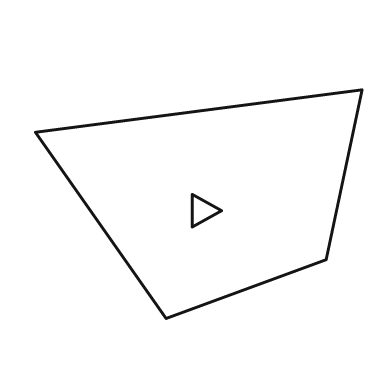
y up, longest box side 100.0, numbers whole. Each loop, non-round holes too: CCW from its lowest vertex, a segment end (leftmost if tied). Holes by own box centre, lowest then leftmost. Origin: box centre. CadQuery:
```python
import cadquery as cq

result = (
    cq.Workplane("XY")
    .moveTo(-10.0, -35.0)
    .lineTo(39.0, -17.0)
    .lineTo(50.0, 35.0)
    .lineTo(-50.0, 22.0)
    .close()
    .moveTo(-2.0, -7.0)
    .lineTo(7.0, -2.0)
    .lineTo(-2.0, 3.0)
    .close()
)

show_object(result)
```